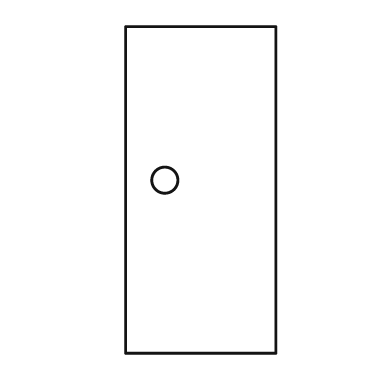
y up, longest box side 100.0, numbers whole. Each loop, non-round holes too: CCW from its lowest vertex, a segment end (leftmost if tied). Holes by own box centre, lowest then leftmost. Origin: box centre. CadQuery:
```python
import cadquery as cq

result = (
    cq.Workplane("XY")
    .moveTo(-23.0, -50.0)
    .lineTo(23.0, -50.0)
    .lineTo(23.0, 50.0)
    .lineTo(-23.0, 50.0)
    .close()
    .moveTo(-11.0, 3.0)
    .circle(4.0)
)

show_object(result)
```